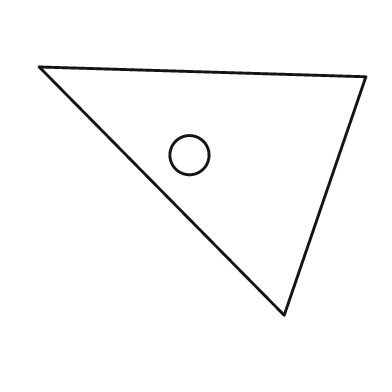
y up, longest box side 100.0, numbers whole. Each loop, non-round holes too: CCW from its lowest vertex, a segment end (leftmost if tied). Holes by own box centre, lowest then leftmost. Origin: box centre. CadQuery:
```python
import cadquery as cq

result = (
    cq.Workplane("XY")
    .moveTo(25.0, -38.0)
    .lineTo(50.0, 35.0)
    .lineTo(-50.0, 38.0)
    .close()
    .moveTo(-4.0, 11.0)
    .circle(6.0)
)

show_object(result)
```